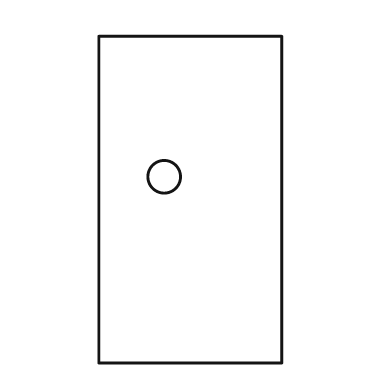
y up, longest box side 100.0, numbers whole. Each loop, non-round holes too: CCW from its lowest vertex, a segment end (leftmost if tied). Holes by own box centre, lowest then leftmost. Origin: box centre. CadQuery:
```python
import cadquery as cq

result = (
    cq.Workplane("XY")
    .moveTo(-28.0, -50.0)
    .lineTo(28.0, -50.0)
    .lineTo(28.0, 50.0)
    .lineTo(-28.0, 50.0)
    .close()
    .moveTo(-8.0, 7.0)
    .circle(5.0)
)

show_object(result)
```